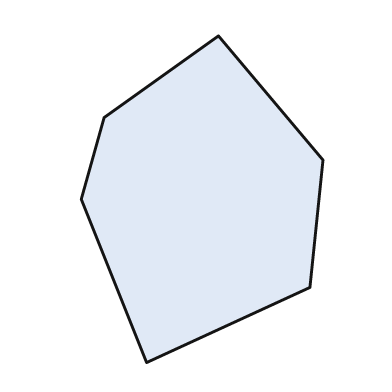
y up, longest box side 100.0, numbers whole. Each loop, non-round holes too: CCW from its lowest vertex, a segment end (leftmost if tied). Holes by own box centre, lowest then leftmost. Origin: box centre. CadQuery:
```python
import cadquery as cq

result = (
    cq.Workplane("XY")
    .moveTo(-17.0, -50.0)
    .lineTo(33.0, -27.0)
    .lineTo(37.0, 12.0)
    .lineTo(5.0, 50.0)
    .lineTo(-30.0, 25.0)
    .lineTo(-37.0, 0.0)
    .close()
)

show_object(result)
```